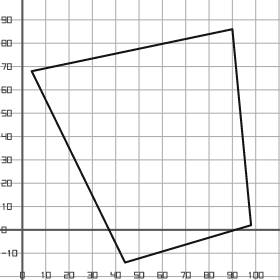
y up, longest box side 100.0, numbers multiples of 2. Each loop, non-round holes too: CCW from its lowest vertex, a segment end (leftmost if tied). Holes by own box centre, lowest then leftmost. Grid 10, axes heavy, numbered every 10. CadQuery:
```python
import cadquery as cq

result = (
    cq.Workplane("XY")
    .moveTo(44.0, -14.0)
    .lineTo(98.0, 2.0)
    .lineTo(90.0, 86.0)
    .lineTo(4.0, 68.0)
    .close()
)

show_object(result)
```